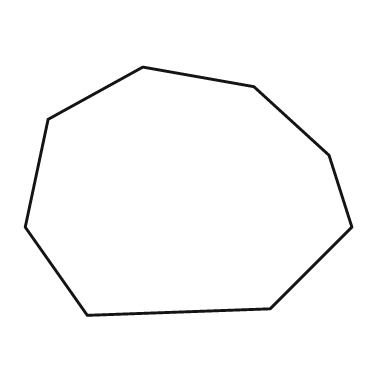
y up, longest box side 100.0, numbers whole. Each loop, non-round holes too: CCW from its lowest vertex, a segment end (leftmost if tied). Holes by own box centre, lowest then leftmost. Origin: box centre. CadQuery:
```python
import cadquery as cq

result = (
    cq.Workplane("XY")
    .moveTo(-31.0, -38.0)
    .lineTo(25.0, -36.0)
    .lineTo(50.0, -11.0)
    .lineTo(43.0, 11.0)
    .lineTo(20.0, 32.0)
    .lineTo(-14.0, 38.0)
    .lineTo(-43.0, 22.0)
    .lineTo(-50.0, -11.0)
    .close()
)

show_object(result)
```